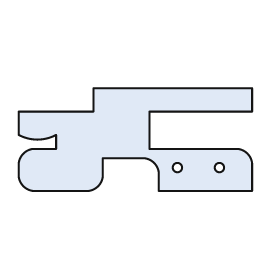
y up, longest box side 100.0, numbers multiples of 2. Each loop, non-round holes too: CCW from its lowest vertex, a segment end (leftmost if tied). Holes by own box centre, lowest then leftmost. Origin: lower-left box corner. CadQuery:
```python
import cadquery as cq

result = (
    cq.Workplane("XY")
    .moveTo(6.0, 0.0)
    .lineTo(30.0, 0.0)
    .threePointArc((34.0, 2.0), (36.0, 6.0))
    .lineTo(36.0, 14.0)
    .lineTo(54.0, 14.0)
    .threePointArc((58.0, 12.0), (60.0, 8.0))
    .lineTo(60.0, 0.0)
    .lineTo(100.0, 0.0)
    .lineTo(100.0, 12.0)
    .threePointArc((98.0, 16.0), (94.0, 18.0))
    .lineTo(56.0, 18.0)
    .lineTo(56.0, 34.0)
    .lineTo(100.0, 34.0)
    .lineTo(100.0, 44.0)
    .lineTo(32.0, 44.0)
    .lineTo(32.0, 34.0)
    .lineTo(0.0, 34.0)
    .lineTo(0.0, 24.0)
    .threePointArc((8.0, 22.0), (16.0, 24.0))
    .lineTo(16.0, 18.0)
    .lineTo(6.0, 18.0)
    .threePointArc((2.0, 16.0), (0.0, 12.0))
    .lineTo(0.0, 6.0)
    .threePointArc((2.0, 2.0), (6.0, 0.0))
    .close()
    .moveTo(68.0, 10.0)
    .circle(2.0)
    .moveTo(86.0, 10.0)
    .circle(2.0)
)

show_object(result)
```